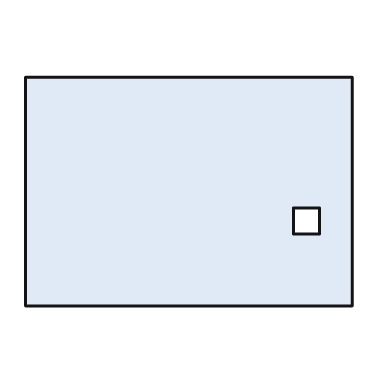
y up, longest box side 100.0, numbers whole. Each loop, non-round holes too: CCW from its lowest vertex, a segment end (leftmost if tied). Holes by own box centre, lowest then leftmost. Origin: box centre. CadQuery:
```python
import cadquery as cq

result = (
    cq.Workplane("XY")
    .moveTo(-50.0, -35.0)
    .lineTo(50.0, -35.0)
    .lineTo(50.0, 35.0)
    .lineTo(-50.0, 35.0)
    .close()
    .moveTo(32.0, -13.0)
    .lineTo(40.0, -13.0)
    .lineTo(40.0, -5.0)
    .lineTo(32.0, -5.0)
    .close()
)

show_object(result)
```